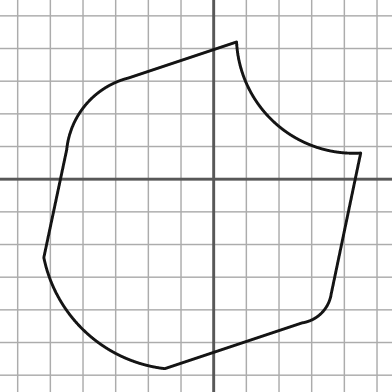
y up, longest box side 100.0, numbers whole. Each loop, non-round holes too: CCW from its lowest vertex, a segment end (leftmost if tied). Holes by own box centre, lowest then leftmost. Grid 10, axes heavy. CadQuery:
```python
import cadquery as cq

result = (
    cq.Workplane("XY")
    .moveTo(-15.0, -58.0)
    .lineTo(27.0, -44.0)
    .threePointArc((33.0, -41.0), (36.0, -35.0))
    .lineTo(45.0, 8.0)
    .threePointArc((19.0, 17.0), (7.0, 42.0))
    .lineTo(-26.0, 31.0)
    .threePointArc((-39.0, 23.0), (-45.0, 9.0))
    .lineTo(-52.0, -24.0)
    .threePointArc((-39.0, -47.0), (-15.0, -58.0))
    .close()
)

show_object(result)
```